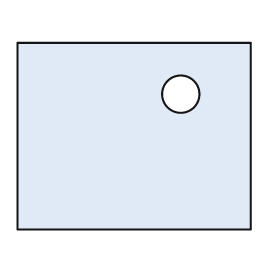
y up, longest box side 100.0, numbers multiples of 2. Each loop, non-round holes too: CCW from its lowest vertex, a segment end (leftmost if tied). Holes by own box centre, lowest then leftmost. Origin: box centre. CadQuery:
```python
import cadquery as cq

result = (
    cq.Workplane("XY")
    .moveTo(-50.0, -40.0)
    .lineTo(50.0, -40.0)
    .lineTo(50.0, 40.0)
    .lineTo(-50.0, 40.0)
    .close()
    .moveTo(20.0, 18.0)
    .circle(8.0)
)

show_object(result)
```